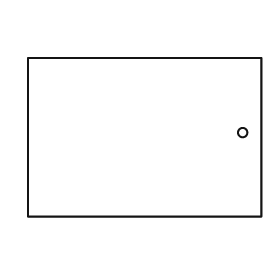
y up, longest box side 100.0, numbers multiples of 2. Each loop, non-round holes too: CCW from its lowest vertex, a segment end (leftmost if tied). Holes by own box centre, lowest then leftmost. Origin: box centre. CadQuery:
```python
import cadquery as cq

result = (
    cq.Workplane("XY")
    .moveTo(-50.0, -34.0)
    .lineTo(50.0, -34.0)
    .lineTo(50.0, 34.0)
    .lineTo(-50.0, 34.0)
    .close()
    .moveTo(42.0, 2.0)
    .circle(2.0)
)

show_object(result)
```